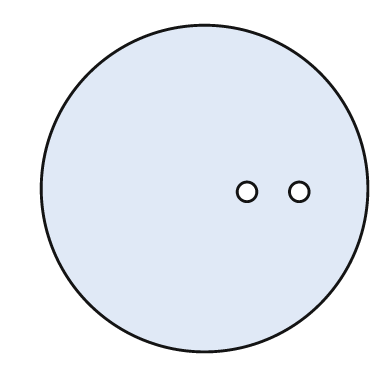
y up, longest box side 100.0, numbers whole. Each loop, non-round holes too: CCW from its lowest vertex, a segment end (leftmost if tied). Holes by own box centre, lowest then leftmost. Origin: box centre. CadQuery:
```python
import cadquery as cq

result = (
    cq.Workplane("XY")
    .moveTo(0.0, 0.0)
    .circle(50.0)
    .moveTo(13.0, -1.0)
    .circle(3.0)
    .moveTo(29.0, -1.0)
    .circle(3.0)
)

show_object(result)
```